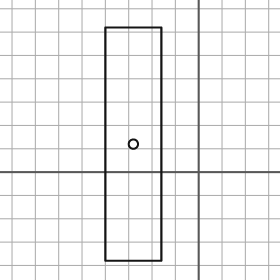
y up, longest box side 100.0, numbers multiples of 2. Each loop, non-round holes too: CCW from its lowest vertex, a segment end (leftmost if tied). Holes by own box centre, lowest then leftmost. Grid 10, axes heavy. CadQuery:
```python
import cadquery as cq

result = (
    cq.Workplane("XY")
    .moveTo(-40.0, -38.0)
    .lineTo(-16.0, -38.0)
    .lineTo(-16.0, 62.0)
    .lineTo(-40.0, 62.0)
    .close()
    .moveTo(-28.0, 12.0)
    .circle(2.0)
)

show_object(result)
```